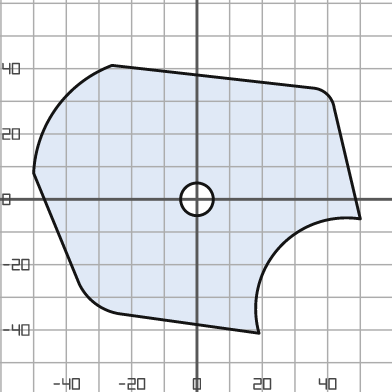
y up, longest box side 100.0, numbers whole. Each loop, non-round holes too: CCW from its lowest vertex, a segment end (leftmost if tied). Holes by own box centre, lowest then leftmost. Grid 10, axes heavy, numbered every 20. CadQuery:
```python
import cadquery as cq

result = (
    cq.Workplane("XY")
    .moveTo(19.0, -41.0)
    .threePointArc((25.0, -15.0), (50.0, -6.0))
    .lineTo(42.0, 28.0)
    .threePointArc((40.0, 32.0), (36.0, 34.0))
    .lineTo(-26.0, 41.0)
    .threePointArc((-43.0, 28.0), (-50.0, 8.0))
    .lineTo(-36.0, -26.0)
    .threePointArc((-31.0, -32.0), (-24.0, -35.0))
    .close()
    .moveTo(0.0, 0.0)
    .circle(5.0)
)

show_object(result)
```